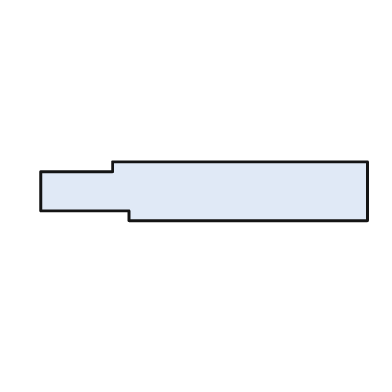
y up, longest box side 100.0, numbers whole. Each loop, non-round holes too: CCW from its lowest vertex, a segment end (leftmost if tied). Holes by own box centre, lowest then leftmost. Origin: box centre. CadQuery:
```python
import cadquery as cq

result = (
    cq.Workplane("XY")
    .moveTo(-23.0, -9.0)
    .lineTo(50.0, -9.0)
    .lineTo(50.0, 9.0)
    .lineTo(-28.0, 9.0)
    .lineTo(-28.0, 6.0)
    .lineTo(-50.0, 6.0)
    .lineTo(-50.0, -6.0)
    .lineTo(-23.0, -6.0)
    .close()
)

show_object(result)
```